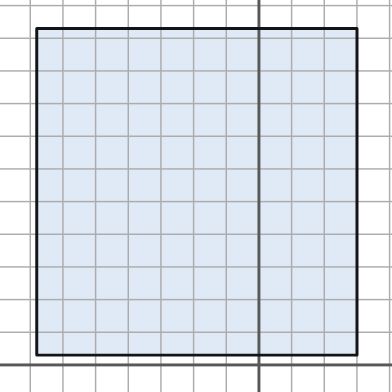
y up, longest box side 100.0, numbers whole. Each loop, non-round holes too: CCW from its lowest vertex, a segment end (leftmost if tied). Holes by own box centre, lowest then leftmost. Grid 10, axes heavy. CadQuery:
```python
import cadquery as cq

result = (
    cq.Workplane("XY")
    .moveTo(-68.0, 3.0)
    .lineTo(30.0, 3.0)
    .lineTo(30.0, 103.0)
    .lineTo(-68.0, 103.0)
    .close()
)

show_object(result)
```